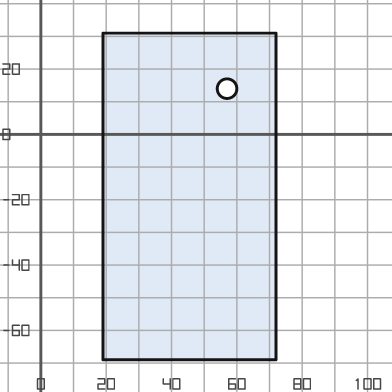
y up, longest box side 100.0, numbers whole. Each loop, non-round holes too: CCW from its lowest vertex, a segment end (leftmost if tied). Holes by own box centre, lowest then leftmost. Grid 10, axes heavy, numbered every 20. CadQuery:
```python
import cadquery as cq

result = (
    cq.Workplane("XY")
    .moveTo(19.0, -69.0)
    .lineTo(72.0, -69.0)
    .lineTo(72.0, 31.0)
    .lineTo(19.0, 31.0)
    .close()
    .moveTo(57.0, 14.0)
    .circle(3.0)
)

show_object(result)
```